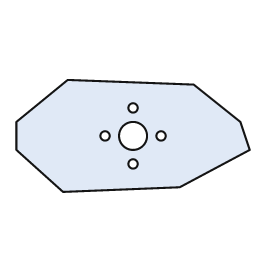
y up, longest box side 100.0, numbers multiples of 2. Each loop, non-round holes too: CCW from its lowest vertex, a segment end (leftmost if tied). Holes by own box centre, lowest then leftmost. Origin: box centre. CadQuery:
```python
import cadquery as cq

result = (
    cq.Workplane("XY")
    .moveTo(-30.0, -24.0)
    .lineTo(20.0, -22.0)
    .lineTo(50.0, -6.0)
    .lineTo(46.0, 6.0)
    .lineTo(26.0, 22.0)
    .lineTo(-28.0, 24.0)
    .lineTo(-50.0, 6.0)
    .lineTo(-50.0, -6.0)
    .close()
    .moveTo(0.0, -12.0)
    .circle(2.0)
    .moveTo(-12.0, 0.0)
    .circle(2.0)
    .moveTo(0.0, 0.0)
    .circle(6.0)
    .moveTo(12.0, 0.0)
    .circle(2.0)
    .moveTo(0.0, 12.0)
    .circle(2.0)
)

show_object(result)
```